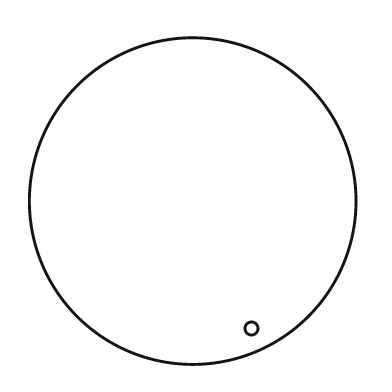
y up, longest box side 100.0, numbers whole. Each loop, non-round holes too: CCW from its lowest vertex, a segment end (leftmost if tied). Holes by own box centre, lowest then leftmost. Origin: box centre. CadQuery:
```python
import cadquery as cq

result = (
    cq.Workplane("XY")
    .moveTo(0.0, 0.0)
    .circle(50.0)
    .moveTo(18.0, -39.0)
    .circle(2.0)
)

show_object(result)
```